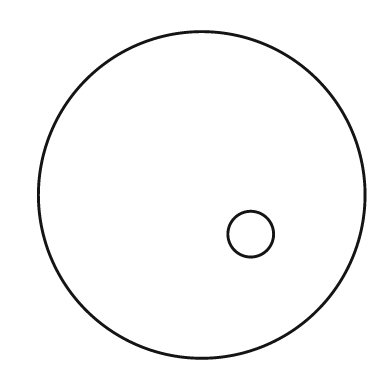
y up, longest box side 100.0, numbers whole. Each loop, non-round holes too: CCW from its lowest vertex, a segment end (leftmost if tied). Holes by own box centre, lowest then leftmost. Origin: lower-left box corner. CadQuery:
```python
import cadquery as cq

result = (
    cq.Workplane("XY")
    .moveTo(50.0, 50.0)
    .circle(50.0)
    .moveTo(65.0, 38.0)
    .circle(7.0)
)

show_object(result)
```